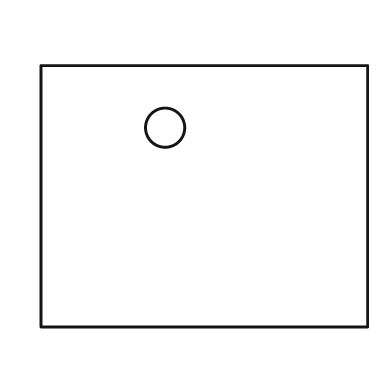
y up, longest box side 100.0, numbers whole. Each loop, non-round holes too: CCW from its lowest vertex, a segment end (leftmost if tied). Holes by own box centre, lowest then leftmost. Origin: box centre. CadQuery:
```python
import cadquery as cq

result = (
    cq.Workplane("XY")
    .moveTo(-50.0, -40.0)
    .lineTo(50.0, -40.0)
    .lineTo(50.0, 40.0)
    .lineTo(-50.0, 40.0)
    .close()
    .moveTo(-12.0, 21.0)
    .circle(6.0)
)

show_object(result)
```